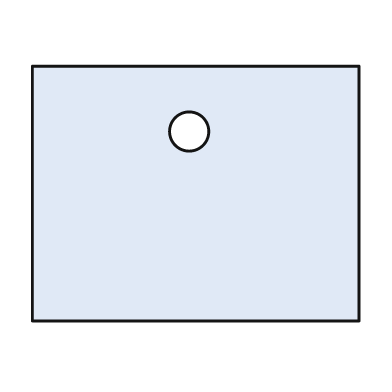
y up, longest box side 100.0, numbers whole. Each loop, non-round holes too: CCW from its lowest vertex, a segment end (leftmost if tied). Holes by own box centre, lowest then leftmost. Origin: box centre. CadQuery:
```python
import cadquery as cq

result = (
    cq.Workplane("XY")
    .moveTo(-50.0, -39.0)
    .lineTo(50.0, -39.0)
    .lineTo(50.0, 39.0)
    .lineTo(-50.0, 39.0)
    .close()
    .moveTo(-2.0, 19.0)
    .circle(6.0)
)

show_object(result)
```